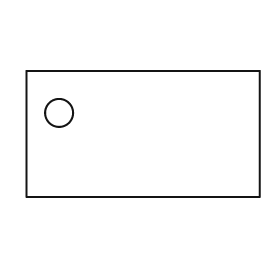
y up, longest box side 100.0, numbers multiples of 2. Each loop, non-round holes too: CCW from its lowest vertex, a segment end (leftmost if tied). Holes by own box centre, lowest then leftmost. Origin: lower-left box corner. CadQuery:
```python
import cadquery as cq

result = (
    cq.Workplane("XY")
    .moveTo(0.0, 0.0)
    .lineTo(100.0, 0.0)
    .lineTo(100.0, 54.0)
    .lineTo(0.0, 54.0)
    .close()
    .moveTo(14.0, 36.0)
    .circle(6.0)
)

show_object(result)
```